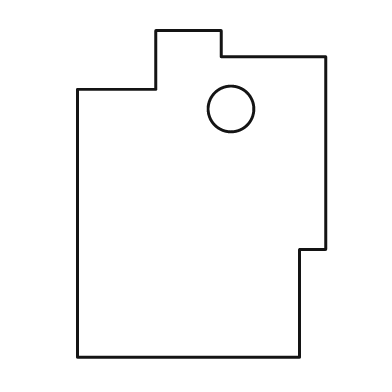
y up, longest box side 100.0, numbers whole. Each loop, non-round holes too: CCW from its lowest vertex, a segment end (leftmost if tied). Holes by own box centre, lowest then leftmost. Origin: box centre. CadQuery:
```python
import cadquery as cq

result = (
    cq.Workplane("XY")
    .moveTo(-38.0, -50.0)
    .lineTo(30.0, -50.0)
    .lineTo(30.0, -17.0)
    .lineTo(38.0, -17.0)
    .lineTo(38.0, 42.0)
    .lineTo(6.0, 42.0)
    .lineTo(6.0, 50.0)
    .lineTo(-14.0, 50.0)
    .lineTo(-14.0, 32.0)
    .lineTo(-38.0, 32.0)
    .close()
    .moveTo(9.0, 26.0)
    .circle(7.0)
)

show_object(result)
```